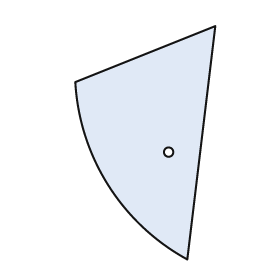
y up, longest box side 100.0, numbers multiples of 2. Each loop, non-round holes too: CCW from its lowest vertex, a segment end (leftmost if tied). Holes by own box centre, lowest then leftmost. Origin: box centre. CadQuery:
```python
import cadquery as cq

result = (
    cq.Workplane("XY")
    .moveTo(18.0, -50.0)
    .lineTo(30.0, 50.0)
    .lineTo(-30.0, 26.0)
    .threePointArc((-16.0, -18.0), (18.0, -50.0))
    .close()
    .moveTo(10.0, -4.0)
    .circle(2.0)
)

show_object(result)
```